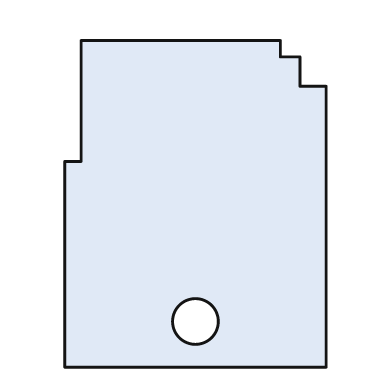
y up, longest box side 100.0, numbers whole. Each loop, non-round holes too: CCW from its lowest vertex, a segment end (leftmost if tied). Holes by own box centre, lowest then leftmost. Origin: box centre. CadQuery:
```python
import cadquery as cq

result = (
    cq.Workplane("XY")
    .moveTo(-40.0, -50.0)
    .lineTo(40.0, -50.0)
    .lineTo(40.0, 36.0)
    .lineTo(32.0, 36.0)
    .lineTo(32.0, 45.0)
    .lineTo(26.0, 45.0)
    .lineTo(26.0, 50.0)
    .lineTo(-35.0, 50.0)
    .lineTo(-35.0, 13.0)
    .lineTo(-40.0, 13.0)
    .close()
    .moveTo(0.0, -36.0)
    .circle(7.0)
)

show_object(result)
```